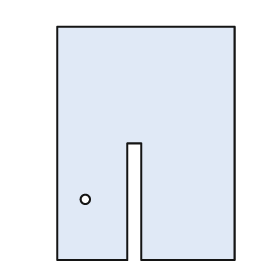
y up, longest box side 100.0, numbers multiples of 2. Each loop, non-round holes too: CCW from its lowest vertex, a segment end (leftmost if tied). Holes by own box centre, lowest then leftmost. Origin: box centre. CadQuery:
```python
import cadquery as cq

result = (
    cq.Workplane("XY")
    .moveTo(-38.0, -50.0)
    .lineTo(-8.0, -50.0)
    .lineTo(-8.0, 0.0)
    .lineTo(-2.0, 0.0)
    .lineTo(-2.0, -50.0)
    .lineTo(38.0, -50.0)
    .lineTo(38.0, 50.0)
    .lineTo(-38.0, 50.0)
    .close()
    .moveTo(-26.0, -24.0)
    .circle(2.0)
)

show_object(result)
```